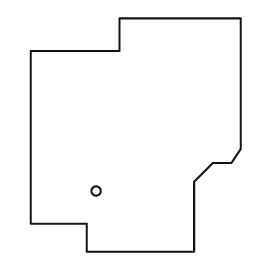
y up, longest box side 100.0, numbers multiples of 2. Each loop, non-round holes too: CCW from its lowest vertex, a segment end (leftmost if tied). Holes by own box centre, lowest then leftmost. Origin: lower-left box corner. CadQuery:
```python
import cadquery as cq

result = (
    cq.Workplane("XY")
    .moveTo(24.0, 0.0)
    .lineTo(70.0, 0.0)
    .lineTo(70.0, 30.0)
    .lineTo(78.0, 38.0)
    .lineTo(86.0, 38.0)
    .lineTo(90.0, 44.0)
    .lineTo(90.0, 100.0)
    .lineTo(38.0, 100.0)
    .lineTo(38.0, 86.0)
    .lineTo(0.0, 86.0)
    .lineTo(0.0, 12.0)
    .lineTo(24.0, 12.0)
    .close()
    .moveTo(28.0, 26.0)
    .circle(2.0)
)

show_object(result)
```